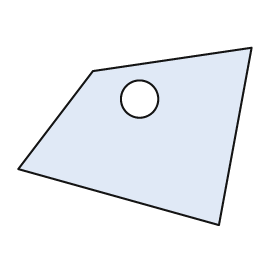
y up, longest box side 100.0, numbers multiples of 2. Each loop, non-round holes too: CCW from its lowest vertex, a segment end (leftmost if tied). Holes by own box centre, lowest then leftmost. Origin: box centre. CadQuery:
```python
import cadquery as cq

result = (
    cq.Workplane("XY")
    .moveTo(36.0, -38.0)
    .lineTo(50.0, 38.0)
    .lineTo(-18.0, 28.0)
    .lineTo(-50.0, -14.0)
    .close()
    .moveTo(2.0, 16.0)
    .circle(8.0)
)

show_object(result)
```